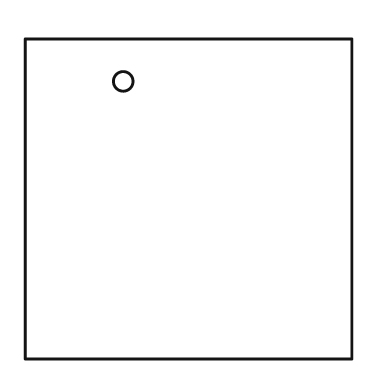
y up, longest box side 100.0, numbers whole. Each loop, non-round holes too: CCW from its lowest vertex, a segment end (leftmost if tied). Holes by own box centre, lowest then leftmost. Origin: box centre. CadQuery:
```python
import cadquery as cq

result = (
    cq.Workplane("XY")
    .moveTo(-50.0, -49.0)
    .lineTo(50.0, -49.0)
    .lineTo(50.0, 49.0)
    .lineTo(-50.0, 49.0)
    .close()
    .moveTo(-20.0, 36.0)
    .circle(3.0)
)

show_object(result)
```